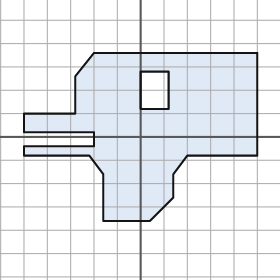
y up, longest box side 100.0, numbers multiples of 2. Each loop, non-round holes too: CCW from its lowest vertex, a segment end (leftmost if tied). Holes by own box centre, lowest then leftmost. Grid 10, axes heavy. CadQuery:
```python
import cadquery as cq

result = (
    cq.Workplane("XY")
    .moveTo(-16.0, -36.0)
    .lineTo(4.0, -36.0)
    .lineTo(14.0, -26.0)
    .lineTo(14.0, -16.0)
    .lineTo(20.0, -8.0)
    .lineTo(50.0, -8.0)
    .lineTo(50.0, 36.0)
    .lineTo(-20.0, 36.0)
    .lineTo(-28.0, 26.0)
    .lineTo(-28.0, 10.0)
    .lineTo(-50.0, 10.0)
    .lineTo(-50.0, 2.0)
    .lineTo(-20.0, 2.0)
    .lineTo(-20.0, -4.0)
    .lineTo(-50.0, -4.0)
    .lineTo(-50.0, -8.0)
    .lineTo(-22.0, -8.0)
    .lineTo(-16.0, -16.0)
    .close()
    .moveTo(0.0, 12.0)
    .lineTo(12.0, 12.0)
    .lineTo(12.0, 28.0)
    .lineTo(0.0, 28.0)
    .close()
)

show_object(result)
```